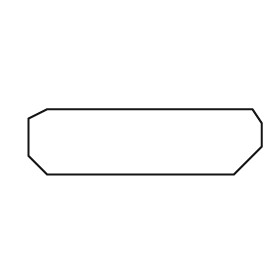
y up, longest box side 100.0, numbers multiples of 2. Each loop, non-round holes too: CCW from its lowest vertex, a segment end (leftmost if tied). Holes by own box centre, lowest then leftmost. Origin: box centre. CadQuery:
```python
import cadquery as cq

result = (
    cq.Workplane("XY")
    .moveTo(-42.0, -14.0)
    .lineTo(38.0, -14.0)
    .lineTo(50.0, -2.0)
    .lineTo(50.0, 8.0)
    .lineTo(46.0, 14.0)
    .lineTo(-42.0, 14.0)
    .lineTo(-50.0, 10.0)
    .lineTo(-50.0, -6.0)
    .close()
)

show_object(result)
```